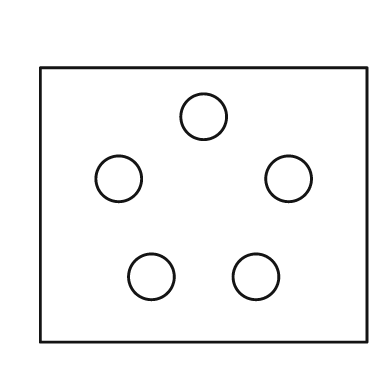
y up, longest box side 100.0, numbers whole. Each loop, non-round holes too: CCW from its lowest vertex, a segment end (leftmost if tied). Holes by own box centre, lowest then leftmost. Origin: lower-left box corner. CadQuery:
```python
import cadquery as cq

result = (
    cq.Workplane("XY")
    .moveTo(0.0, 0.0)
    .lineTo(100.0, 0.0)
    .lineTo(100.0, 84.0)
    .lineTo(0.0, 84.0)
    .close()
    .moveTo(34.0, 20.0)
    .circle(7.0)
    .moveTo(66.0, 20.0)
    .circle(7.0)
    .moveTo(24.0, 50.0)
    .circle(7.0)
    .moveTo(76.0, 50.0)
    .circle(7.0)
    .moveTo(50.0, 69.0)
    .circle(7.0)
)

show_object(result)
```